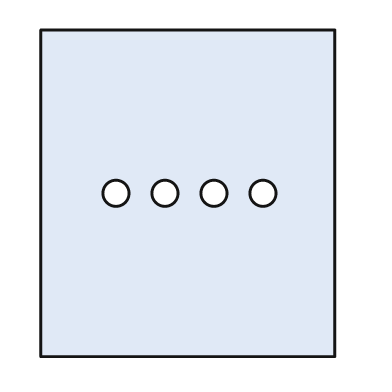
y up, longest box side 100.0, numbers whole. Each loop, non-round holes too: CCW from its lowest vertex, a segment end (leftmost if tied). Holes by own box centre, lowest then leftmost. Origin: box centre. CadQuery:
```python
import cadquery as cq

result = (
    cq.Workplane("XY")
    .moveTo(-45.0, -50.0)
    .lineTo(45.0, -50.0)
    .lineTo(45.0, 50.0)
    .lineTo(-45.0, 50.0)
    .close()
    .moveTo(-22.0, 0.0)
    .circle(4.0)
    .moveTo(-7.0, 0.0)
    .circle(4.0)
    .moveTo(8.0, 0.0)
    .circle(4.0)
    .moveTo(23.0, 0.0)
    .circle(4.0)
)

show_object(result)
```